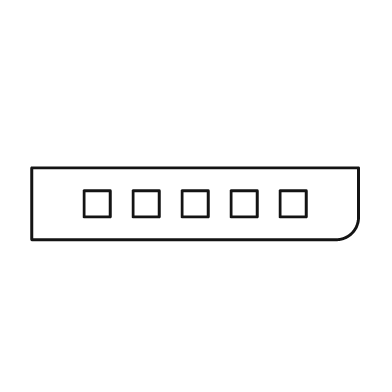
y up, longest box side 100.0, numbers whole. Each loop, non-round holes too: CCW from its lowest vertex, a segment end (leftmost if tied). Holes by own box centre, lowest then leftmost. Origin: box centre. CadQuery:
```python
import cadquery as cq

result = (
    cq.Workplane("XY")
    .moveTo(-50.0, -11.0)
    .lineTo(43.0, -11.0)
    .threePointArc((48.0, -9.0), (50.0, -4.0))
    .lineTo(50.0, 11.0)
    .lineTo(-50.0, 11.0)
    .close()
    .moveTo(-34.0, -4.0)
    .lineTo(-26.0, -4.0)
    .lineTo(-26.0, 4.0)
    .lineTo(-34.0, 4.0)
    .close()
    .moveTo(-19.0, -4.0)
    .lineTo(-11.0, -4.0)
    .lineTo(-11.0, 4.0)
    .lineTo(-19.0, 4.0)
    .close()
    .moveTo(-4.0, -4.0)
    .lineTo(4.0, -4.0)
    .lineTo(4.0, 4.0)
    .lineTo(-4.0, 4.0)
    .close()
    .moveTo(11.0, -4.0)
    .lineTo(19.0, -4.0)
    .lineTo(19.0, 4.0)
    .lineTo(11.0, 4.0)
    .close()
    .moveTo(26.0, -4.0)
    .lineTo(34.0, -4.0)
    .lineTo(34.0, 4.0)
    .lineTo(26.0, 4.0)
    .close()
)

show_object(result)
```